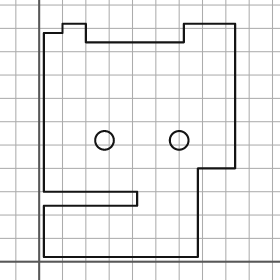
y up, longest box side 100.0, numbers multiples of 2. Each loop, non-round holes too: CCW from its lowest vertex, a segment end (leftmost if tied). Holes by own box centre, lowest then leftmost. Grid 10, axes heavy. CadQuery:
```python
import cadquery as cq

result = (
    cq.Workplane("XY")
    .moveTo(2.0, 2.0)
    .lineTo(68.0, 2.0)
    .lineTo(68.0, 40.0)
    .lineTo(84.0, 40.0)
    .lineTo(84.0, 102.0)
    .lineTo(62.0, 102.0)
    .lineTo(62.0, 94.0)
    .lineTo(20.0, 94.0)
    .lineTo(20.0, 102.0)
    .lineTo(10.0, 102.0)
    .lineTo(10.0, 98.0)
    .lineTo(2.0, 98.0)
    .lineTo(2.0, 30.0)
    .lineTo(42.0, 30.0)
    .lineTo(42.0, 24.0)
    .lineTo(2.0, 24.0)
    .close()
    .moveTo(28.0, 52.0)
    .circle(4.0)
    .moveTo(60.0, 52.0)
    .circle(4.0)
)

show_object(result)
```